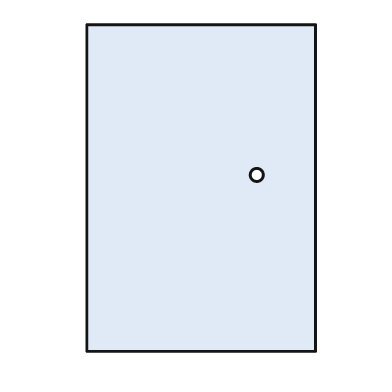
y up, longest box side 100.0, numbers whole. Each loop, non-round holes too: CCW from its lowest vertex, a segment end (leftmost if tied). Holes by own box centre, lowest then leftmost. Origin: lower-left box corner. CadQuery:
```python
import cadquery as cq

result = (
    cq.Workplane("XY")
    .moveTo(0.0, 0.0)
    .lineTo(70.0, 0.0)
    .lineTo(70.0, 100.0)
    .lineTo(0.0, 100.0)
    .close()
    .moveTo(52.0, 54.0)
    .circle(2.0)
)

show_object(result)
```